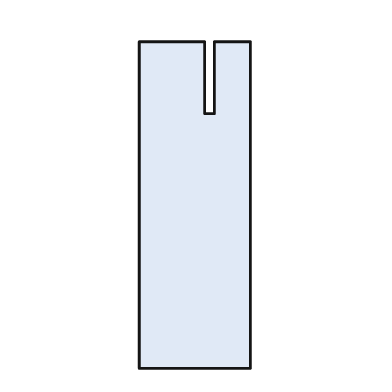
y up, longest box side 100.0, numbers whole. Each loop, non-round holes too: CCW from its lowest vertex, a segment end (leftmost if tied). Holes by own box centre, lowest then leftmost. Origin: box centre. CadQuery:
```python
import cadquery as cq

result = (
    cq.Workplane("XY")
    .moveTo(-17.0, -50.0)
    .lineTo(17.0, -50.0)
    .lineTo(17.0, 50.0)
    .lineTo(6.0, 50.0)
    .lineTo(6.0, 28.0)
    .lineTo(3.0, 28.0)
    .lineTo(3.0, 50.0)
    .lineTo(-17.0, 50.0)
    .close()
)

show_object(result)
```